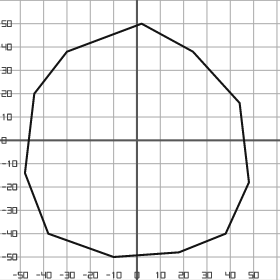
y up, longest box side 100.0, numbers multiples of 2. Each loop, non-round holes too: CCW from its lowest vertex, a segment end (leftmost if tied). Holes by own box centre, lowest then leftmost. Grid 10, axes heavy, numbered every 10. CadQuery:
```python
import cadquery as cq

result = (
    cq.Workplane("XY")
    .moveTo(-10.0, -50.0)
    .lineTo(18.0, -48.0)
    .lineTo(38.0, -40.0)
    .lineTo(48.0, -18.0)
    .lineTo(44.0, 16.0)
    .lineTo(24.0, 38.0)
    .lineTo(2.0, 50.0)
    .lineTo(-30.0, 38.0)
    .lineTo(-44.0, 20.0)
    .lineTo(-48.0, -14.0)
    .lineTo(-38.0, -40.0)
    .close()
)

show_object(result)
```